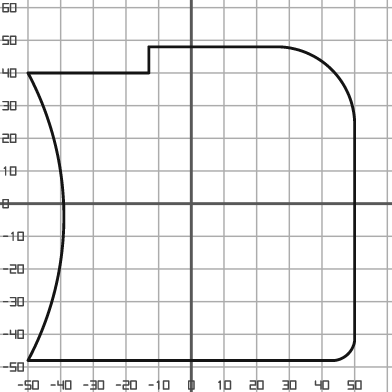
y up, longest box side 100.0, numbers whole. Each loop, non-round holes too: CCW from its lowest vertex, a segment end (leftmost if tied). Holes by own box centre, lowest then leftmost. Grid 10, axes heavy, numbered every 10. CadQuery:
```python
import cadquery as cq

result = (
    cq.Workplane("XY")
    .moveTo(-50.0, -48.0)
    .lineTo(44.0, -48.0)
    .threePointArc((48.0, -46.0), (50.0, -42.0))
    .lineTo(50.0, 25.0)
    .threePointArc((43.0, 41.0), (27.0, 48.0))
    .lineTo(-13.0, 48.0)
    .lineTo(-13.0, 40.0)
    .lineTo(-50.0, 40.0)
    .threePointArc((-39.0, -4.0), (-50.0, -48.0))
    .close()
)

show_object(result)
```